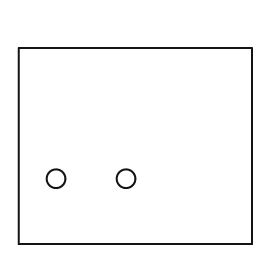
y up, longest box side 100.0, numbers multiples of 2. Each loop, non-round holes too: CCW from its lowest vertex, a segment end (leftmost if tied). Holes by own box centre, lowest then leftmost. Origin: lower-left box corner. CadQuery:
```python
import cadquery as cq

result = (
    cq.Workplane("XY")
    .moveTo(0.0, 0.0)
    .lineTo(100.0, 0.0)
    .lineTo(100.0, 84.0)
    .lineTo(0.0, 84.0)
    .close()
    .moveTo(16.0, 28.0)
    .circle(4.0)
    .moveTo(46.0, 28.0)
    .circle(4.0)
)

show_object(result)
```